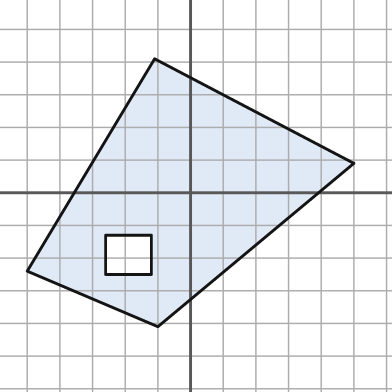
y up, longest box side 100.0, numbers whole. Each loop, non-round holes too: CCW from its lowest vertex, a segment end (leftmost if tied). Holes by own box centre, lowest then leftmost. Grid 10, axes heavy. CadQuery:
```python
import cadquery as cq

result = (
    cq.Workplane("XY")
    .moveTo(-10.0, -41.0)
    .lineTo(50.0, 9.0)
    .lineTo(-11.0, 41.0)
    .lineTo(-50.0, -24.0)
    .close()
    .moveTo(-26.0, -25.0)
    .lineTo(-12.0, -25.0)
    .lineTo(-12.0, -13.0)
    .lineTo(-26.0, -13.0)
    .close()
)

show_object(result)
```